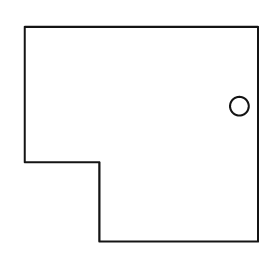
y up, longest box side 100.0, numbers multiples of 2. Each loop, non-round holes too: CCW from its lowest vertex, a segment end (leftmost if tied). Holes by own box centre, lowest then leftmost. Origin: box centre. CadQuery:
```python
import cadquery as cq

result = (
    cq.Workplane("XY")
    .moveTo(-18.0, -46.0)
    .lineTo(50.0, -46.0)
    .lineTo(50.0, 46.0)
    .lineTo(-50.0, 46.0)
    .lineTo(-50.0, -12.0)
    .lineTo(-18.0, -12.0)
    .close()
    .moveTo(42.0, 12.0)
    .circle(4.0)
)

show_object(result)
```